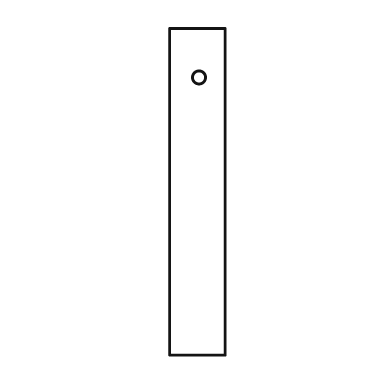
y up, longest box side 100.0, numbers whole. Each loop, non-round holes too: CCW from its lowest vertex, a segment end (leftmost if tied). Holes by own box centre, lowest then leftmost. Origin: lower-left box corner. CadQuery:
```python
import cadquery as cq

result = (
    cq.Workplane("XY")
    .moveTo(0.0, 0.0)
    .lineTo(17.0, 0.0)
    .lineTo(17.0, 100.0)
    .lineTo(0.0, 100.0)
    .close()
    .moveTo(9.0, 85.0)
    .circle(2.0)
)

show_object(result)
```